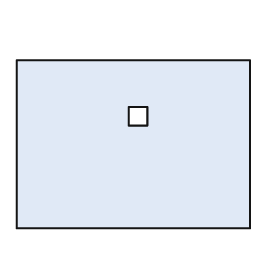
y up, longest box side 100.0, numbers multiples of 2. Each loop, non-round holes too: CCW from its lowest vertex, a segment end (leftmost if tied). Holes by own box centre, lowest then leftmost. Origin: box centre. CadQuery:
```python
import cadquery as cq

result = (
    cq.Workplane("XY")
    .moveTo(-50.0, -36.0)
    .lineTo(50.0, -36.0)
    .lineTo(50.0, 36.0)
    .lineTo(-50.0, 36.0)
    .close()
    .moveTo(-2.0, 8.0)
    .lineTo(6.0, 8.0)
    .lineTo(6.0, 16.0)
    .lineTo(-2.0, 16.0)
    .close()
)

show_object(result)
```